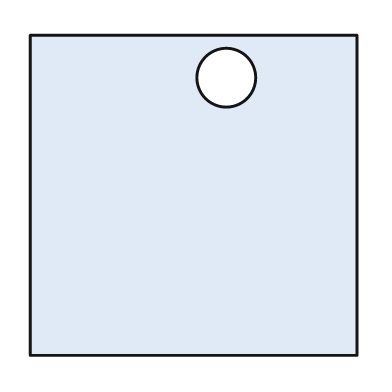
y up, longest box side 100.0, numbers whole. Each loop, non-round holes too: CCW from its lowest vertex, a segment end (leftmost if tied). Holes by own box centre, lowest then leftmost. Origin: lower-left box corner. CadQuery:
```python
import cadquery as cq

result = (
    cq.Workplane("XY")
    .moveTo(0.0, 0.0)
    .lineTo(100.0, 0.0)
    .lineTo(100.0, 98.0)
    .lineTo(0.0, 98.0)
    .close()
    .moveTo(60.0, 85.0)
    .circle(9.0)
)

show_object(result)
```